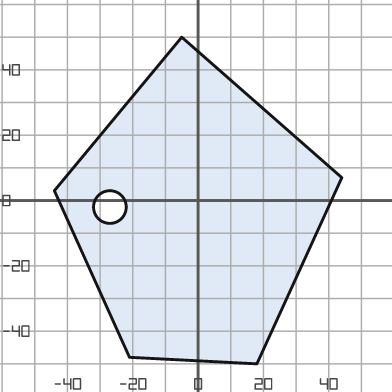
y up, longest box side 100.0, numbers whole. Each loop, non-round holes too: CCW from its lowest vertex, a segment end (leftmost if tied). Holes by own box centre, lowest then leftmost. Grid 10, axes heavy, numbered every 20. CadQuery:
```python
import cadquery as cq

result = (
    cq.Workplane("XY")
    .moveTo(18.0, -50.0)
    .lineTo(44.0, 7.0)
    .lineTo(-5.0, 50.0)
    .lineTo(-44.0, 3.0)
    .lineTo(-21.0, -48.0)
    .close()
    .moveTo(-27.0, -2.0)
    .circle(5.0)
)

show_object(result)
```